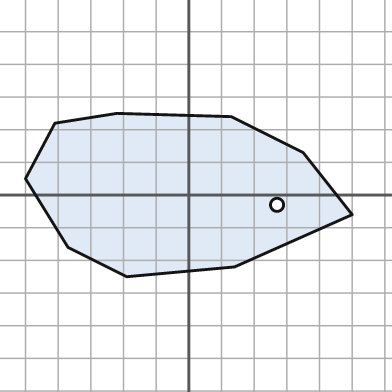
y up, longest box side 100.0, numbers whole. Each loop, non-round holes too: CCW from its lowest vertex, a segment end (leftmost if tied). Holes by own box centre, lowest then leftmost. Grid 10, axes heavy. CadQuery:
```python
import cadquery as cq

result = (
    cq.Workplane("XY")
    .moveTo(-19.0, -25.0)
    .lineTo(14.0, -22.0)
    .lineTo(50.0, -6.0)
    .lineTo(35.0, 13.0)
    .lineTo(13.0, 24.0)
    .lineTo(-22.0, 25.0)
    .lineTo(-41.0, 22.0)
    .lineTo(-50.0, 5.0)
    .lineTo(-37.0, -16.0)
    .close()
    .moveTo(27.0, -3.0)
    .circle(2.0)
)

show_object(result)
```